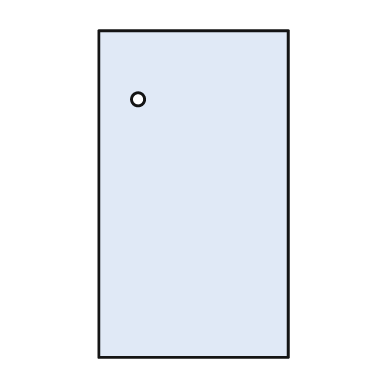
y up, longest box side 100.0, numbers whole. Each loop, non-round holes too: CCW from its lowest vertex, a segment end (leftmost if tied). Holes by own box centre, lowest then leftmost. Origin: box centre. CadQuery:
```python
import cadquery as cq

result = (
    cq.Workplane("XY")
    .moveTo(-29.0, -50.0)
    .lineTo(29.0, -50.0)
    .lineTo(29.0, 50.0)
    .lineTo(-29.0, 50.0)
    .close()
    .moveTo(-17.0, 29.0)
    .circle(2.0)
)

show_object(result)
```